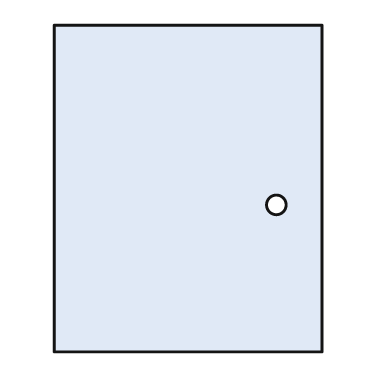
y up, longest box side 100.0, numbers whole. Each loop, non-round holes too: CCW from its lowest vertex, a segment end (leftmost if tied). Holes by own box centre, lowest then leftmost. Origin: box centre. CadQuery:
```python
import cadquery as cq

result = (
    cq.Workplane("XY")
    .moveTo(-41.0, -50.0)
    .lineTo(41.0, -50.0)
    .lineTo(41.0, 50.0)
    .lineTo(-41.0, 50.0)
    .close()
    .moveTo(27.0, -5.0)
    .circle(3.0)
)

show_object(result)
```